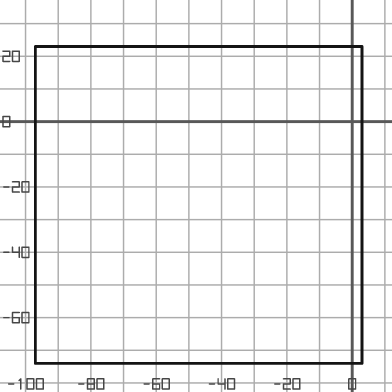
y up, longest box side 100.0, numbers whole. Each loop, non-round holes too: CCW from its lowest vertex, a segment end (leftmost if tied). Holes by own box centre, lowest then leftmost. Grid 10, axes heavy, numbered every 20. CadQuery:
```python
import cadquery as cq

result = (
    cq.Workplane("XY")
    .moveTo(-97.0, -74.0)
    .lineTo(3.0, -74.0)
    .lineTo(3.0, 23.0)
    .lineTo(-97.0, 23.0)
    .close()
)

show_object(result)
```